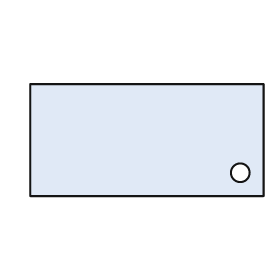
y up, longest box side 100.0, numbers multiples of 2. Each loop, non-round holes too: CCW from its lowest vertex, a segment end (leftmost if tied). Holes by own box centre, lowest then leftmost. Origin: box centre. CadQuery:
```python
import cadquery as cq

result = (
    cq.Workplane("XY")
    .moveTo(-50.0, -24.0)
    .lineTo(50.0, -24.0)
    .lineTo(50.0, 24.0)
    .lineTo(-50.0, 24.0)
    .close()
    .moveTo(40.0, -14.0)
    .circle(4.0)
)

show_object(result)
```